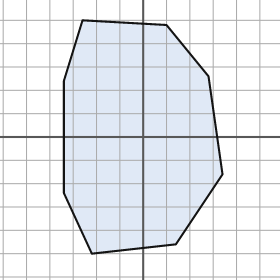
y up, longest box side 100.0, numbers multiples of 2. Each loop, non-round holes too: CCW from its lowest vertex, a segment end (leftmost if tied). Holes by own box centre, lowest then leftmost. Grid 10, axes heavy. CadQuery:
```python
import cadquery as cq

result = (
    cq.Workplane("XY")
    .moveTo(-22.0, -50.0)
    .lineTo(14.0, -46.0)
    .lineTo(34.0, -16.0)
    .lineTo(28.0, 26.0)
    .lineTo(10.0, 48.0)
    .lineTo(-26.0, 50.0)
    .lineTo(-34.0, 24.0)
    .lineTo(-34.0, -24.0)
    .close()
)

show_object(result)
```